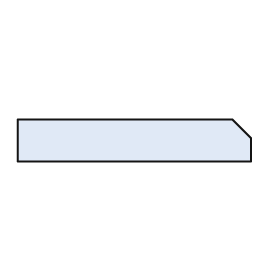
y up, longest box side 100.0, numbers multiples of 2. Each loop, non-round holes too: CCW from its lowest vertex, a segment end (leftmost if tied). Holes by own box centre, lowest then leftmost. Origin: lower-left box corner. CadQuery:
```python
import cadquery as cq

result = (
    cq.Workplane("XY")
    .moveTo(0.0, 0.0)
    .lineTo(100.0, 0.0)
    .lineTo(100.0, 10.0)
    .lineTo(92.0, 18.0)
    .lineTo(0.0, 18.0)
    .close()
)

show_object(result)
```